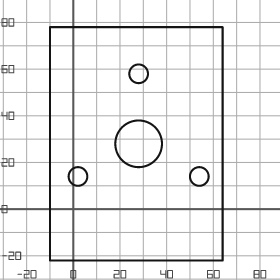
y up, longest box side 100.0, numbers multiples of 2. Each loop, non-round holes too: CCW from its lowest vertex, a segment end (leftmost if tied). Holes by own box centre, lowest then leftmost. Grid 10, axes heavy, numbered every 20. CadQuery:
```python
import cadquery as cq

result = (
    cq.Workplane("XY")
    .moveTo(-10.0, -22.0)
    .lineTo(64.0, -22.0)
    .lineTo(64.0, 78.0)
    .lineTo(-10.0, 78.0)
    .close()
    .moveTo(2.0, 14.0)
    .circle(4.0)
    .moveTo(54.0, 14.0)
    .circle(4.0)
    .moveTo(28.0, 28.0)
    .circle(10.0)
    .moveTo(28.0, 58.0)
    .circle(4.0)
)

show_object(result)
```